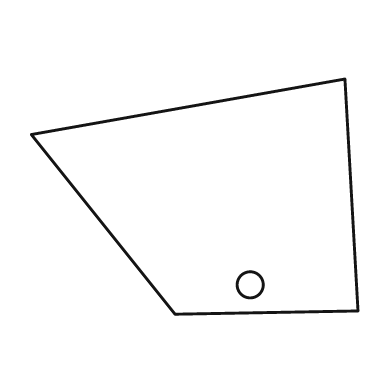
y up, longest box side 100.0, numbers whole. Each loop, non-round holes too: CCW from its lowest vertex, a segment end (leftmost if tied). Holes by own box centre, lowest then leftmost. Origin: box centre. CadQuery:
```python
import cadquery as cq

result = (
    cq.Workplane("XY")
    .moveTo(-6.0, -36.0)
    .lineTo(50.0, -35.0)
    .lineTo(46.0, 36.0)
    .lineTo(-50.0, 19.0)
    .close()
    .moveTo(17.0, -27.0)
    .circle(4.0)
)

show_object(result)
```